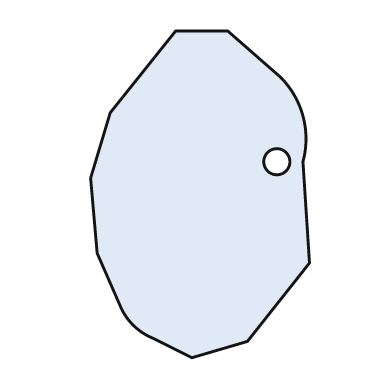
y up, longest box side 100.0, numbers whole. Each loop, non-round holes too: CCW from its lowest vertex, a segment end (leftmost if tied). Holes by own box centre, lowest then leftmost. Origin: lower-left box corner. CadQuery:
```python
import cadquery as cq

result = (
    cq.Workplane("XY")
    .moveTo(31.0, 0.0)
    .lineTo(48.0, 5.0)
    .lineTo(67.0, 29.0)
    .lineTo(65.0, 60.0)
    .threePointArc((65.0, 74.0), (58.0, 86.0))
    .lineTo(42.0, 100.0)
    .lineTo(26.0, 100.0)
    .lineTo(6.0, 75.0)
    .lineTo(0.0, 55.0)
    .lineTo(2.0, 32.0)
    .lineTo(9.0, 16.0)
    .threePointArc((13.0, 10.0), (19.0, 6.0))
    .close()
    .moveTo(57.0, 60.0)
    .circle(4.0)
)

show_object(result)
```